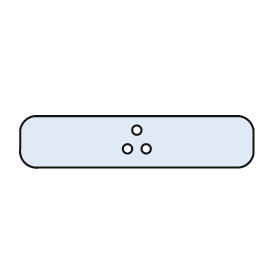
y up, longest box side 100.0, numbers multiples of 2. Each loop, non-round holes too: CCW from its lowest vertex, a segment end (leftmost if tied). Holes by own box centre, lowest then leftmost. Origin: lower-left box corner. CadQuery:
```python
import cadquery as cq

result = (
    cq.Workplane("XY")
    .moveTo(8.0, 0.0)
    .lineTo(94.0, 0.0)
    .threePointArc((98.0, 2.0), (100.0, 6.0))
    .lineTo(100.0, 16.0)
    .threePointArc((98.0, 20.0), (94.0, 22.0))
    .lineTo(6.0, 22.0)
    .threePointArc((2.0, 20.0), (0.0, 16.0))
    .lineTo(0.0, 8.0)
    .threePointArc((2.0, 2.0), (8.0, 0.0))
    .close()
    .moveTo(46.0, 8.0)
    .circle(2.0)
    .moveTo(54.0, 8.0)
    .circle(2.0)
    .moveTo(50.0, 16.0)
    .circle(2.0)
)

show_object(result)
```